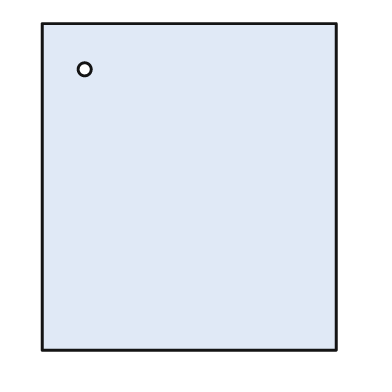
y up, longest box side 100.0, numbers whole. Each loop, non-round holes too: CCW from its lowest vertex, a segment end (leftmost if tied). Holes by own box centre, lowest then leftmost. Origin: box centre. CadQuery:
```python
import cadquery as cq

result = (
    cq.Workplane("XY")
    .moveTo(-45.0, -50.0)
    .lineTo(45.0, -50.0)
    .lineTo(45.0, 50.0)
    .lineTo(-45.0, 50.0)
    .close()
    .moveTo(-32.0, 36.0)
    .circle(2.0)
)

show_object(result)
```